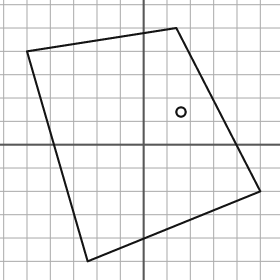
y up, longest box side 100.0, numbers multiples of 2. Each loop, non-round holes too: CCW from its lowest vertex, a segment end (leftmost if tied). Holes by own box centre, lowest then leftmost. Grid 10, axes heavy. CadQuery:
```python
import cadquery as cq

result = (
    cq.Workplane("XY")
    .moveTo(-24.0, -50.0)
    .lineTo(50.0, -20.0)
    .lineTo(14.0, 50.0)
    .lineTo(-50.0, 40.0)
    .close()
    .moveTo(16.0, 14.0)
    .circle(2.0)
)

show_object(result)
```